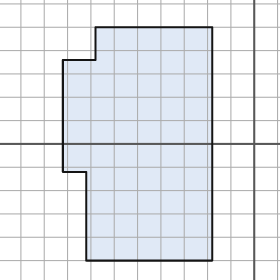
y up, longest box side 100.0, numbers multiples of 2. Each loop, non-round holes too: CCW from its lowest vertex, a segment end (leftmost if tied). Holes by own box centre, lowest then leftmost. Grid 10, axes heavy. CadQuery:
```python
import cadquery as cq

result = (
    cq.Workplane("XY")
    .moveTo(-72.0, -50.0)
    .lineTo(-18.0, -50.0)
    .lineTo(-18.0, 50.0)
    .lineTo(-68.0, 50.0)
    .lineTo(-68.0, 36.0)
    .lineTo(-82.0, 36.0)
    .lineTo(-82.0, -12.0)
    .lineTo(-72.0, -12.0)
    .close()
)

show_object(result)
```